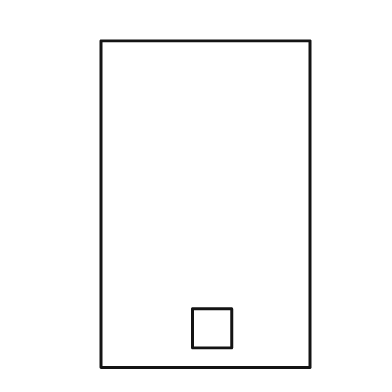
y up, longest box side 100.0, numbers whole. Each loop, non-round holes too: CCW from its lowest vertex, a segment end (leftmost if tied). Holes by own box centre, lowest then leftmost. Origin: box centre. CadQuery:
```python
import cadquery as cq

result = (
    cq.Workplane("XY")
    .moveTo(-32.0, -50.0)
    .lineTo(32.0, -50.0)
    .lineTo(32.0, 50.0)
    .lineTo(-32.0, 50.0)
    .close()
    .moveTo(-4.0, -44.0)
    .lineTo(8.0, -44.0)
    .lineTo(8.0, -32.0)
    .lineTo(-4.0, -32.0)
    .close()
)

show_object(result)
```